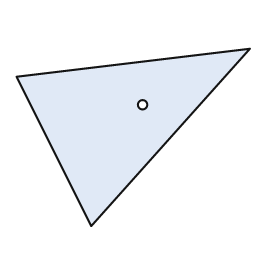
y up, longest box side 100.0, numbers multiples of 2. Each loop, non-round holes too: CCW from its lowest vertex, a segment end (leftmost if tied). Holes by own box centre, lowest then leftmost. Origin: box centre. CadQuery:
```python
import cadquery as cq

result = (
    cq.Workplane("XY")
    .moveTo(-18.0, -38.0)
    .lineTo(50.0, 38.0)
    .lineTo(-50.0, 26.0)
    .close()
    .moveTo(4.0, 14.0)
    .circle(2.0)
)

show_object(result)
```